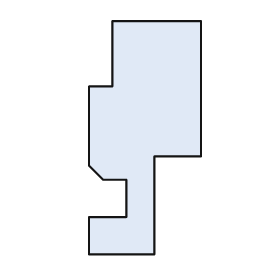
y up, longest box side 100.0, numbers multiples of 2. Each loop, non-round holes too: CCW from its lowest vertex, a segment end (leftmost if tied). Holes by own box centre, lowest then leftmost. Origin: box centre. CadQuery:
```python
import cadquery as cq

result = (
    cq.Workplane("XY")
    .moveTo(-24.0, -50.0)
    .lineTo(4.0, -50.0)
    .lineTo(4.0, -8.0)
    .lineTo(24.0, -8.0)
    .lineTo(24.0, 50.0)
    .lineTo(-14.0, 50.0)
    .lineTo(-14.0, 22.0)
    .lineTo(-24.0, 22.0)
    .lineTo(-24.0, -12.0)
    .lineTo(-18.0, -18.0)
    .lineTo(-8.0, -18.0)
    .lineTo(-8.0, -34.0)
    .lineTo(-24.0, -34.0)
    .close()
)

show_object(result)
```